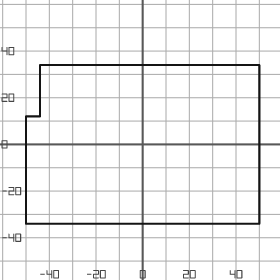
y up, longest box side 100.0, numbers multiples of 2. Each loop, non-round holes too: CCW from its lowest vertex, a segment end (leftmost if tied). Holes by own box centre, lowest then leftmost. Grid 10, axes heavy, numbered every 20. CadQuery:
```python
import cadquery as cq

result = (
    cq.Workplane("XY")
    .moveTo(-50.0, -34.0)
    .lineTo(50.0, -34.0)
    .lineTo(50.0, 34.0)
    .lineTo(-44.0, 34.0)
    .lineTo(-44.0, 12.0)
    .lineTo(-50.0, 12.0)
    .close()
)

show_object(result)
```